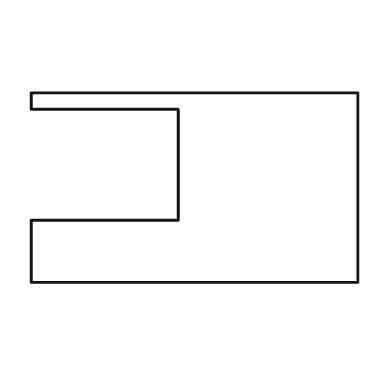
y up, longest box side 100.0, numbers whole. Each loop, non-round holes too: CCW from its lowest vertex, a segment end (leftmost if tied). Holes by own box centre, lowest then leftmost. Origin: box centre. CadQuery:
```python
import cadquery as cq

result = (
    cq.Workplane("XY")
    .moveTo(-50.0, -29.0)
    .lineTo(50.0, -29.0)
    .lineTo(50.0, 29.0)
    .lineTo(-50.0, 29.0)
    .lineTo(-50.0, 24.0)
    .lineTo(-5.0, 24.0)
    .lineTo(-5.0, -10.0)
    .lineTo(-50.0, -10.0)
    .close()
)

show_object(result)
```